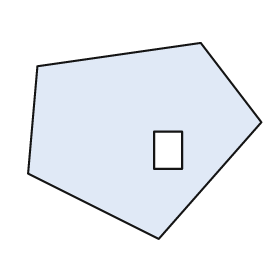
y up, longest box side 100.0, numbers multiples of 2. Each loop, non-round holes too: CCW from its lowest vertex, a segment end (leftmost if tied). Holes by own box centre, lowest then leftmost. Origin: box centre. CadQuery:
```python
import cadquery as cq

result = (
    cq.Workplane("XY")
    .moveTo(6.0, -42.0)
    .lineTo(50.0, 8.0)
    .lineTo(24.0, 42.0)
    .lineTo(-46.0, 32.0)
    .lineTo(-50.0, -14.0)
    .close()
    .moveTo(4.0, -12.0)
    .lineTo(16.0, -12.0)
    .lineTo(16.0, 4.0)
    .lineTo(4.0, 4.0)
    .close()
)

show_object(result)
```